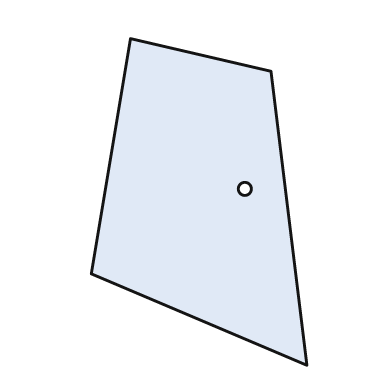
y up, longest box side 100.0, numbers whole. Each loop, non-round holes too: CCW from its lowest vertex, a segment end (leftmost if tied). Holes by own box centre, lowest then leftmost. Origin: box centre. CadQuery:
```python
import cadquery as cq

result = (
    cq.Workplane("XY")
    .moveTo(33.0, -50.0)
    .lineTo(22.0, 40.0)
    .lineTo(-21.0, 50.0)
    .lineTo(-33.0, -22.0)
    .close()
    .moveTo(14.0, 4.0)
    .circle(2.0)
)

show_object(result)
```